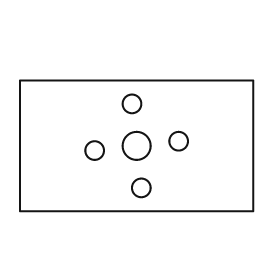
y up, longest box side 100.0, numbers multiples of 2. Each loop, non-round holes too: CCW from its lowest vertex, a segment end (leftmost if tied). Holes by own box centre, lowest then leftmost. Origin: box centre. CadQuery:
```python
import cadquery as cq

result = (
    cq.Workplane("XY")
    .moveTo(-50.0, -28.0)
    .lineTo(50.0, -28.0)
    .lineTo(50.0, 28.0)
    .lineTo(-50.0, 28.0)
    .close()
    .moveTo(2.0, -18.0)
    .circle(4.0)
    .moveTo(-18.0, -2.0)
    .circle(4.0)
    .moveTo(0.0, 0.0)
    .circle(6.0)
    .moveTo(18.0, 2.0)
    .circle(4.0)
    .moveTo(-2.0, 18.0)
    .circle(4.0)
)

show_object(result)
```